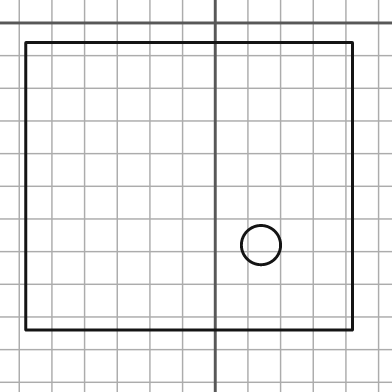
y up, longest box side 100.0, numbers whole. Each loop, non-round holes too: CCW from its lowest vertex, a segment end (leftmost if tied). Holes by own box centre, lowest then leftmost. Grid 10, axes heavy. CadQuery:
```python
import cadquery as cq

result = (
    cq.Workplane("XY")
    .moveTo(-58.0, -94.0)
    .lineTo(42.0, -94.0)
    .lineTo(42.0, -6.0)
    .lineTo(-58.0, -6.0)
    .close()
    .moveTo(14.0, -68.0)
    .circle(6.0)
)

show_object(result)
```